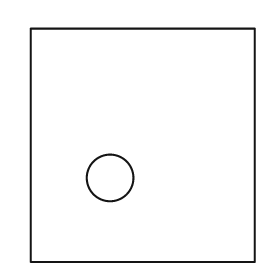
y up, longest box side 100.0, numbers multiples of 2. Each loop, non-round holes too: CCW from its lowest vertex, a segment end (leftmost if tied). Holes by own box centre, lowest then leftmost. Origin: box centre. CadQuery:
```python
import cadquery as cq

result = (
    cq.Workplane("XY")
    .moveTo(-48.0, -50.0)
    .lineTo(48.0, -50.0)
    .lineTo(48.0, 50.0)
    .lineTo(-48.0, 50.0)
    .close()
    .moveTo(-14.0, -14.0)
    .circle(10.0)
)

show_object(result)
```